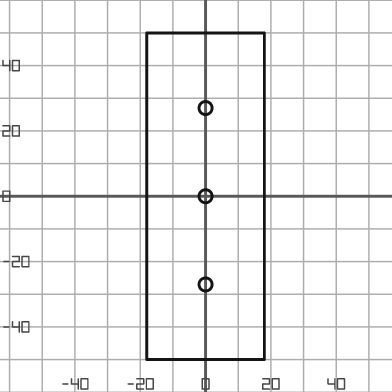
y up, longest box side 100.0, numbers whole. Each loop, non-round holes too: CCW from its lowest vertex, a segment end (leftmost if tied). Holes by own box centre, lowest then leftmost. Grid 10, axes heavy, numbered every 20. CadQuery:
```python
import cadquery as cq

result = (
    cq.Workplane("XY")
    .moveTo(-18.0, -50.0)
    .lineTo(18.0, -50.0)
    .lineTo(18.0, 50.0)
    .lineTo(-18.0, 50.0)
    .close()
    .moveTo(0.0, -27.0)
    .circle(2.0)
    .moveTo(0.0, 0.0)
    .circle(2.0)
    .moveTo(0.0, 27.0)
    .circle(2.0)
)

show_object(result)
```